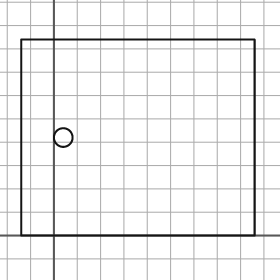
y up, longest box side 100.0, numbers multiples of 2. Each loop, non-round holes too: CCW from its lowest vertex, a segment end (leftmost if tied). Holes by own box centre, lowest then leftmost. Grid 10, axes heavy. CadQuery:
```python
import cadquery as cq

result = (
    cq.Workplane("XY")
    .moveTo(-14.0, 0.0)
    .lineTo(86.0, 0.0)
    .lineTo(86.0, 84.0)
    .lineTo(-14.0, 84.0)
    .close()
    .moveTo(4.0, 42.0)
    .circle(4.0)
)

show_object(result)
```